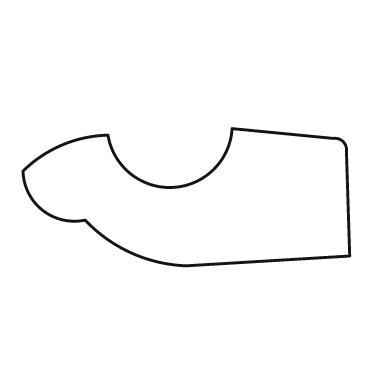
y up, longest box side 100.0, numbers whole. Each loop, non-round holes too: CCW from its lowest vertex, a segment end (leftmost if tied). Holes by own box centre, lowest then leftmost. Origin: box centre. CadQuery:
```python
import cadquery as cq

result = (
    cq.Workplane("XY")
    .moveTo(0.0, -21.0)
    .lineTo(50.0, -18.0)
    .lineTo(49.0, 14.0)
    .threePointArc((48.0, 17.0), (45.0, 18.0))
    .lineTo(14.0, 21.0)
    .threePointArc((-4.0, 3.0), (-24.0, 19.0))
    .threePointArc((-38.0, 16.0), (-50.0, 8.0))
    .threePointArc((-44.0, -4.0), (-31.0, -7.0))
    .threePointArc((-17.0, -17.0), (0.0, -21.0))
    .close()
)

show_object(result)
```